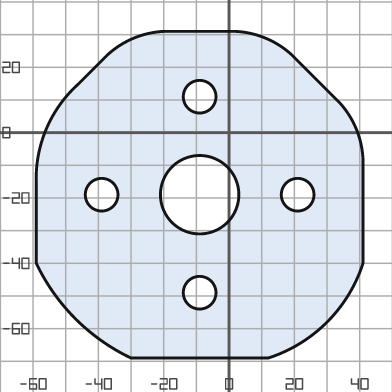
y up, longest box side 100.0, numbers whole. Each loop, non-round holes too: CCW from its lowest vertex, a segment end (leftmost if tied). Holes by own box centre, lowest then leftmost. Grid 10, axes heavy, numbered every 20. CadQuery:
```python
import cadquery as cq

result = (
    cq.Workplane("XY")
    .moveTo(-30.0, -69.0)
    .lineTo(12.0, -69.0)
    .threePointArc((30.0, -58.0), (41.0, -40.0))
    .lineTo(41.0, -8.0)
    .threePointArc((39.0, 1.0), (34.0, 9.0))
    .lineTo(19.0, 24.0)
    .threePointArc((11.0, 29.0), (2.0, 31.0))
    .lineTo(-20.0, 31.0)
    .threePointArc((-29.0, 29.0), (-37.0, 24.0))
    .lineTo(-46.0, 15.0)
    .threePointArc((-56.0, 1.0), (-59.0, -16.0))
    .lineTo(-59.0, -40.0)
    .threePointArc((-47.0, -57.0), (-30.0, -69.0))
    .close()
    .moveTo(-9.0, -49.0)
    .circle(5.0)
    .moveTo(-39.0, -19.0)
    .circle(5.0)
    .moveTo(-9.0, -19.0)
    .circle(12.0)
    .moveTo(21.0, -19.0)
    .circle(5.0)
    .moveTo(-9.0, 11.0)
    .circle(5.0)
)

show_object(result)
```